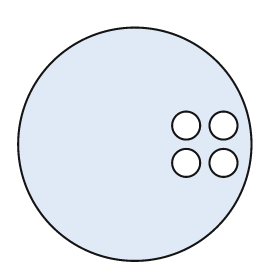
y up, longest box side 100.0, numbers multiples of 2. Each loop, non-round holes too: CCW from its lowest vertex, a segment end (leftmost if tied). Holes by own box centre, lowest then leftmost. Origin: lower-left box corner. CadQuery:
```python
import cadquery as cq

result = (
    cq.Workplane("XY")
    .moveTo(50.0, 50.0)
    .circle(50.0)
    .moveTo(72.0, 42.0)
    .circle(6.0)
    .moveTo(88.0, 42.0)
    .circle(6.0)
    .moveTo(72.0, 58.0)
    .circle(6.0)
    .moveTo(88.0, 58.0)
    .circle(6.0)
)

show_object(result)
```